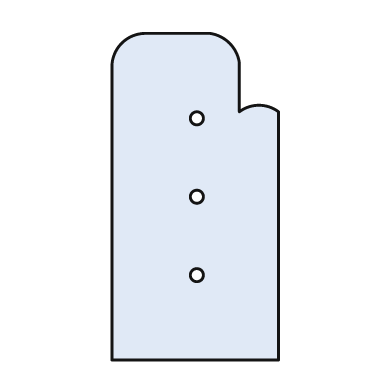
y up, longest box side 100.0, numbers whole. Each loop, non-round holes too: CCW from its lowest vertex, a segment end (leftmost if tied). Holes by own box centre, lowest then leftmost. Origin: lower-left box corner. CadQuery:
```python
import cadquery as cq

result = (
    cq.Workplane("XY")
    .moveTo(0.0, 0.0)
    .lineTo(51.0, 0.0)
    .lineTo(51.0, 76.0)
    .threePointArc((45.0, 78.0), (39.0, 76.0))
    .lineTo(39.0, 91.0)
    .threePointArc((36.0, 97.0), (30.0, 100.0))
    .lineTo(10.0, 100.0)
    .threePointArc((3.0, 97.0), (0.0, 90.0))
    .close()
    .moveTo(26.0, 26.0)
    .circle(2.0)
    .moveTo(26.0, 50.0)
    .circle(2.0)
    .moveTo(26.0, 74.0)
    .circle(2.0)
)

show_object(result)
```